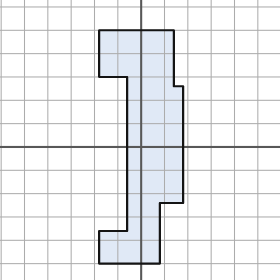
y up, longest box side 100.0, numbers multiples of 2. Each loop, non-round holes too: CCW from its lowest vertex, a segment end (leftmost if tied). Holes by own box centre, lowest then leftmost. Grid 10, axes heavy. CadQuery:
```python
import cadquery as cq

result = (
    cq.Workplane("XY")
    .moveTo(-18.0, -50.0)
    .lineTo(8.0, -50.0)
    .lineTo(8.0, -24.0)
    .lineTo(18.0, -24.0)
    .lineTo(18.0, 26.0)
    .lineTo(14.0, 26.0)
    .lineTo(14.0, 50.0)
    .lineTo(-18.0, 50.0)
    .lineTo(-18.0, 30.0)
    .lineTo(-6.0, 30.0)
    .lineTo(-6.0, -36.0)
    .lineTo(-18.0, -36.0)
    .close()
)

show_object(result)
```